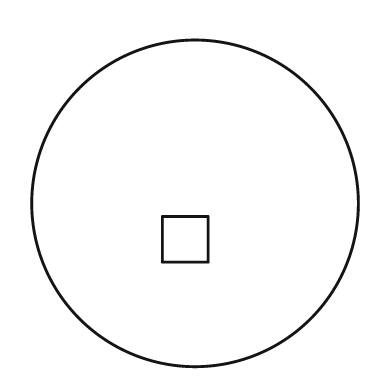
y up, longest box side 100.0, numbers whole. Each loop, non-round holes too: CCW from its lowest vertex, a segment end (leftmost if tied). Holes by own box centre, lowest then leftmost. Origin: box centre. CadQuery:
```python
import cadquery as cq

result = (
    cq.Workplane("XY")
    .moveTo(0.0, 0.0)
    .circle(50.0)
    .moveTo(-10.0, -18.0)
    .lineTo(4.0, -18.0)
    .lineTo(4.0, -4.0)
    .lineTo(-10.0, -4.0)
    .close()
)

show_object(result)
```